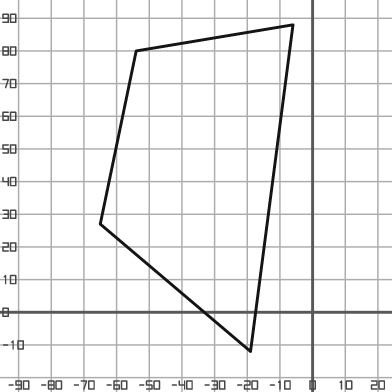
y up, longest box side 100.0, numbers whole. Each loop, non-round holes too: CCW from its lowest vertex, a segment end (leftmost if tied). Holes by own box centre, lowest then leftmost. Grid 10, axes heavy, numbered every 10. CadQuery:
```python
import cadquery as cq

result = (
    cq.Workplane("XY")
    .moveTo(-19.0, -12.0)
    .lineTo(-6.0, 88.0)
    .lineTo(-54.0, 80.0)
    .lineTo(-65.0, 27.0)
    .close()
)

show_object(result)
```